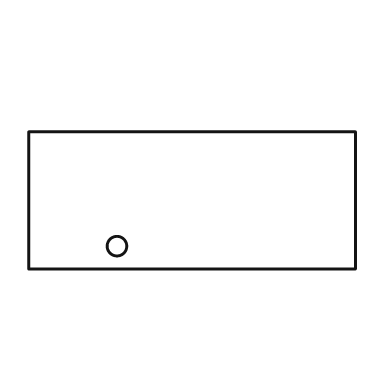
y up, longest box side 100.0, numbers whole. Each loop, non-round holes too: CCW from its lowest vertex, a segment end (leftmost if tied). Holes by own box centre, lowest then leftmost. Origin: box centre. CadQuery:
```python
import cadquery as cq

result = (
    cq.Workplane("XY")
    .moveTo(-50.0, -21.0)
    .lineTo(50.0, -21.0)
    .lineTo(50.0, 21.0)
    .lineTo(-50.0, 21.0)
    .close()
    .moveTo(-23.0, -14.0)
    .circle(3.0)
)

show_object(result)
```